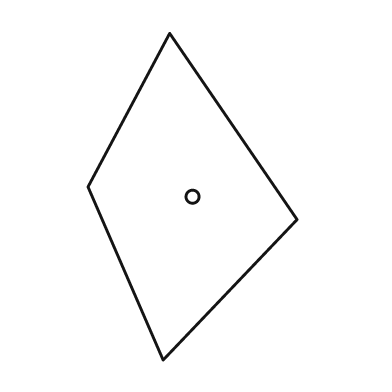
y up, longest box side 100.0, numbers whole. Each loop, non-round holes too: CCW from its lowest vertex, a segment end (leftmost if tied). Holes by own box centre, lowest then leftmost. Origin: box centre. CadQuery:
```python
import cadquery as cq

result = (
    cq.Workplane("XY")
    .moveTo(-9.0, -50.0)
    .lineTo(32.0, -7.0)
    .lineTo(-7.0, 50.0)
    .lineTo(-32.0, 3.0)
    .close()
    .moveTo(0.0, 0.0)
    .circle(2.0)
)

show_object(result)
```